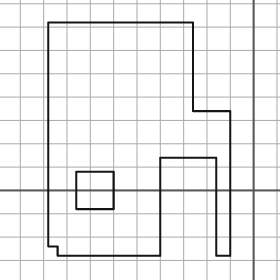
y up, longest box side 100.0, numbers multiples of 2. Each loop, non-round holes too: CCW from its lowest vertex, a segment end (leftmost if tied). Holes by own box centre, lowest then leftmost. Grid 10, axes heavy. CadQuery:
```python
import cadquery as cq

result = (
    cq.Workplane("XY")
    .moveTo(-84.0, -28.0)
    .lineTo(-40.0, -28.0)
    .lineTo(-40.0, 14.0)
    .lineTo(-16.0, 14.0)
    .lineTo(-16.0, -28.0)
    .lineTo(-10.0, -28.0)
    .lineTo(-10.0, 34.0)
    .lineTo(-26.0, 34.0)
    .lineTo(-26.0, 72.0)
    .lineTo(-88.0, 72.0)
    .lineTo(-88.0, -24.0)
    .lineTo(-84.0, -24.0)
    .close()
    .moveTo(-76.0, -8.0)
    .lineTo(-60.0, -8.0)
    .lineTo(-60.0, 8.0)
    .lineTo(-76.0, 8.0)
    .close()
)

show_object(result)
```